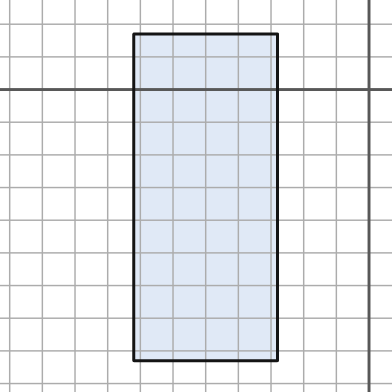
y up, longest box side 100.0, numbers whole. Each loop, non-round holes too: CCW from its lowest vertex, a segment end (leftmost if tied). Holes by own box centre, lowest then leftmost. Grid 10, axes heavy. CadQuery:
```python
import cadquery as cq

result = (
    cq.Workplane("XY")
    .moveTo(-72.0, -83.0)
    .lineTo(-28.0, -83.0)
    .lineTo(-28.0, 17.0)
    .lineTo(-72.0, 17.0)
    .close()
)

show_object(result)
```